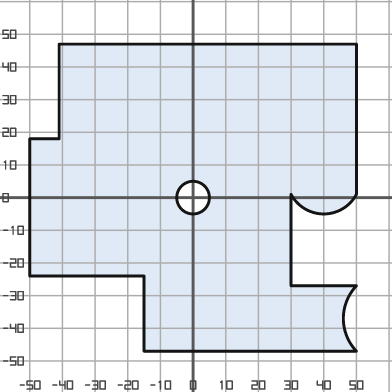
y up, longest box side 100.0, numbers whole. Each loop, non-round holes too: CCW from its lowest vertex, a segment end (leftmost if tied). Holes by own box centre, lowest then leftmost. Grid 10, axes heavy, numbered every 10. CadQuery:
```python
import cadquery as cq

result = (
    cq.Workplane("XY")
    .moveTo(-15.0, -47.0)
    .lineTo(50.0, -47.0)
    .threePointArc((46.0, -37.0), (50.0, -27.0))
    .lineTo(30.0, -27.0)
    .lineTo(30.0, 1.0)
    .threePointArc((40.0, -5.0), (50.0, 1.0))
    .lineTo(50.0, 47.0)
    .lineTo(-41.0, 47.0)
    .lineTo(-41.0, 18.0)
    .lineTo(-50.0, 18.0)
    .lineTo(-50.0, -24.0)
    .lineTo(-15.0, -24.0)
    .close()
    .moveTo(0.0, 0.0)
    .circle(5.0)
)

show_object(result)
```